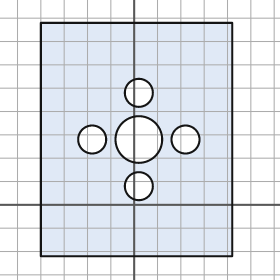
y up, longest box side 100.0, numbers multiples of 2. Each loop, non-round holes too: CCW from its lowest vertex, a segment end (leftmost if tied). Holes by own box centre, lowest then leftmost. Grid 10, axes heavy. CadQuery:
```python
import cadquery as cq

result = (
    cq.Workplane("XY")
    .moveTo(-40.0, -22.0)
    .lineTo(42.0, -22.0)
    .lineTo(42.0, 78.0)
    .lineTo(-40.0, 78.0)
    .close()
    .moveTo(2.0, 8.0)
    .circle(6.0)
    .moveTo(-18.0, 28.0)
    .circle(6.0)
    .moveTo(2.0, 28.0)
    .circle(10.0)
    .moveTo(22.0, 28.0)
    .circle(6.0)
    .moveTo(2.0, 48.0)
    .circle(6.0)
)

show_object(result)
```